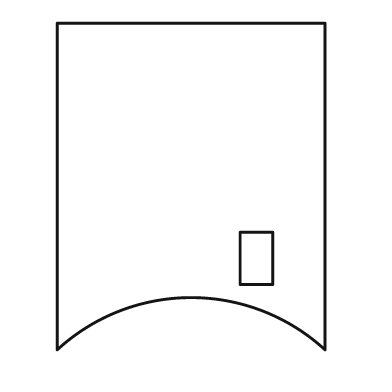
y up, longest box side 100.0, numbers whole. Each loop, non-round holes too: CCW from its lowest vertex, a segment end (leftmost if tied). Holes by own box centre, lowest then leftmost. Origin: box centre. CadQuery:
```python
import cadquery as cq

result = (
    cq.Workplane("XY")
    .moveTo(-41.0, -50.0)
    .threePointArc((0.0, -34.0), (41.0, -50.0))
    .lineTo(41.0, 50.0)
    .lineTo(-41.0, 50.0)
    .close()
    .moveTo(15.0, -30.0)
    .lineTo(25.0, -30.0)
    .lineTo(25.0, -14.0)
    .lineTo(15.0, -14.0)
    .close()
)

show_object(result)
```